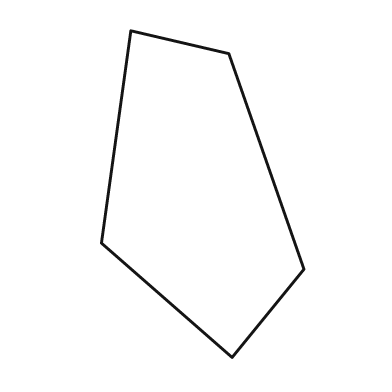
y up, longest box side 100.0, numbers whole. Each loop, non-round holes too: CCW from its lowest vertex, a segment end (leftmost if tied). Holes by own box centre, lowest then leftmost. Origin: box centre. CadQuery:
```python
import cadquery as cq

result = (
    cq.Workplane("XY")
    .moveTo(9.0, -50.0)
    .lineTo(31.0, -23.0)
    .lineTo(8.0, 43.0)
    .lineTo(-22.0, 50.0)
    .lineTo(-31.0, -15.0)
    .close()
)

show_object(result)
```